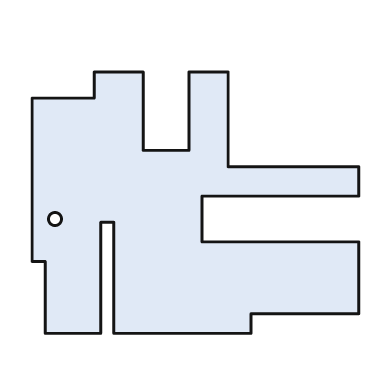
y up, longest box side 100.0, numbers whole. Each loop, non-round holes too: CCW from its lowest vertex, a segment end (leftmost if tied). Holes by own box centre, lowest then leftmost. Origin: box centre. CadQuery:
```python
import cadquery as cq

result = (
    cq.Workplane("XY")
    .moveTo(-46.0, -40.0)
    .lineTo(-29.0, -40.0)
    .lineTo(-29.0, -6.0)
    .lineTo(-25.0, -6.0)
    .lineTo(-25.0, -40.0)
    .lineTo(17.0, -40.0)
    .lineTo(17.0, -34.0)
    .lineTo(50.0, -34.0)
    .lineTo(50.0, -12.0)
    .lineTo(2.0, -12.0)
    .lineTo(2.0, 2.0)
    .lineTo(50.0, 2.0)
    .lineTo(50.0, 11.0)
    .lineTo(10.0, 11.0)
    .lineTo(10.0, 40.0)
    .lineTo(-2.0, 40.0)
    .lineTo(-2.0, 16.0)
    .lineTo(-16.0, 16.0)
    .lineTo(-16.0, 40.0)
    .lineTo(-31.0, 40.0)
    .lineTo(-31.0, 32.0)
    .lineTo(-50.0, 32.0)
    .lineTo(-50.0, -18.0)
    .lineTo(-46.0, -18.0)
    .close()
    .moveTo(-43.0, -5.0)
    .circle(2.0)
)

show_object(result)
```